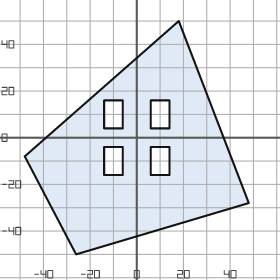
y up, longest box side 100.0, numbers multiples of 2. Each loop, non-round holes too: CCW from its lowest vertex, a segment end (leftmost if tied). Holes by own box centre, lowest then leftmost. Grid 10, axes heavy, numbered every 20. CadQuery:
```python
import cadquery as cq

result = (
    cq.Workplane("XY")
    .moveTo(-26.0, -50.0)
    .lineTo(48.0, -28.0)
    .lineTo(18.0, 50.0)
    .lineTo(-48.0, -8.0)
    .close()
    .moveTo(-14.0, -16.0)
    .lineTo(-6.0, -16.0)
    .lineTo(-6.0, -4.0)
    .lineTo(-14.0, -4.0)
    .close()
    .moveTo(6.0, -16.0)
    .lineTo(14.0, -16.0)
    .lineTo(14.0, -4.0)
    .lineTo(6.0, -4.0)
    .close()
    .moveTo(-14.0, 4.0)
    .lineTo(-6.0, 4.0)
    .lineTo(-6.0, 16.0)
    .lineTo(-14.0, 16.0)
    .close()
    .moveTo(6.0, 4.0)
    .lineTo(14.0, 4.0)
    .lineTo(14.0, 16.0)
    .lineTo(6.0, 16.0)
    .close()
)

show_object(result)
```